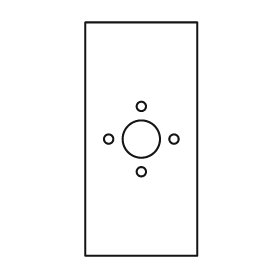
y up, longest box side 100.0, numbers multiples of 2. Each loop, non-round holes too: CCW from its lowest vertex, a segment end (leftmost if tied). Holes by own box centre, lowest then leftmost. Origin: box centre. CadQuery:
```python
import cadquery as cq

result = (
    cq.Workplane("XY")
    .moveTo(-24.0, -50.0)
    .lineTo(24.0, -50.0)
    .lineTo(24.0, 50.0)
    .lineTo(-24.0, 50.0)
    .close()
    .moveTo(0.0, -14.0)
    .circle(2.0)
    .moveTo(-14.0, 0.0)
    .circle(2.0)
    .moveTo(0.0, 0.0)
    .circle(8.0)
    .moveTo(14.0, 0.0)
    .circle(2.0)
    .moveTo(0.0, 14.0)
    .circle(2.0)
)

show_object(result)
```